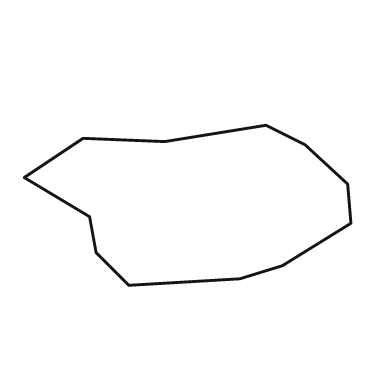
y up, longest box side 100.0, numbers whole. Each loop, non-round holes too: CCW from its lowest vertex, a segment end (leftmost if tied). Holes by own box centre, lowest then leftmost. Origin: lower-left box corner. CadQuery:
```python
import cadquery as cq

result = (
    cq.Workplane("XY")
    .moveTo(32.0, 0.0)
    .lineTo(66.0, 2.0)
    .lineTo(79.0, 6.0)
    .lineTo(100.0, 19.0)
    .lineTo(99.0, 31.0)
    .lineTo(86.0, 43.0)
    .lineTo(74.0, 49.0)
    .lineTo(43.0, 44.0)
    .lineTo(18.0, 45.0)
    .lineTo(0.0, 33.0)
    .lineTo(20.0, 21.0)
    .lineTo(22.0, 10.0)
    .close()
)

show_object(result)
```